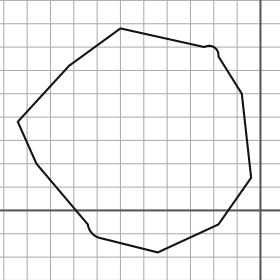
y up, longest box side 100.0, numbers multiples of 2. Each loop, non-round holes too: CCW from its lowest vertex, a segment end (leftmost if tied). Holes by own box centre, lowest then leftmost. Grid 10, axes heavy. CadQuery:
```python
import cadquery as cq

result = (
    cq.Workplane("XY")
    .moveTo(-44.0, -18.0)
    .lineTo(-18.0, -6.0)
    .lineTo(-4.0, 14.0)
    .lineTo(-8.0, 50.0)
    .lineTo(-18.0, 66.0)
    .threePointArc((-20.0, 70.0), (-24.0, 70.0))
    .lineTo(-60.0, 78.0)
    .lineTo(-82.0, 62.0)
    .lineTo(-104.0, 38.0)
    .lineTo(-96.0, 20.0)
    .lineTo(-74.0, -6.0)
    .threePointArc((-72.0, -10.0), (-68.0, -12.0))
    .close()
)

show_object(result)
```